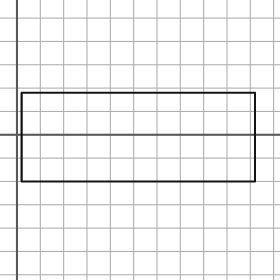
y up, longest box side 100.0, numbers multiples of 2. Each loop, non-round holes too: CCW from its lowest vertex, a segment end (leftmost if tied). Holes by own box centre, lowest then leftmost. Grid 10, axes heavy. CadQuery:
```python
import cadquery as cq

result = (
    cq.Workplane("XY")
    .moveTo(2.0, -20.0)
    .lineTo(102.0, -20.0)
    .lineTo(102.0, 18.0)
    .lineTo(2.0, 18.0)
    .close()
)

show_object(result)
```